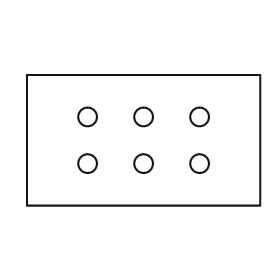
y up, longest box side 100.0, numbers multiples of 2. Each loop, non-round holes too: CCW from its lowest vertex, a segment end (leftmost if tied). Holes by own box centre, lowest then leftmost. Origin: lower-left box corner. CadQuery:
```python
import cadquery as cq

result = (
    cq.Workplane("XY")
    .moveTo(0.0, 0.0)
    .lineTo(100.0, 0.0)
    .lineTo(100.0, 56.0)
    .lineTo(0.0, 56.0)
    .close()
    .moveTo(26.0, 18.0)
    .circle(4.0)
    .moveTo(50.0, 18.0)
    .circle(4.0)
    .moveTo(74.0, 18.0)
    .circle(4.0)
    .moveTo(26.0, 38.0)
    .circle(4.0)
    .moveTo(50.0, 38.0)
    .circle(4.0)
    .moveTo(74.0, 38.0)
    .circle(4.0)
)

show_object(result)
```